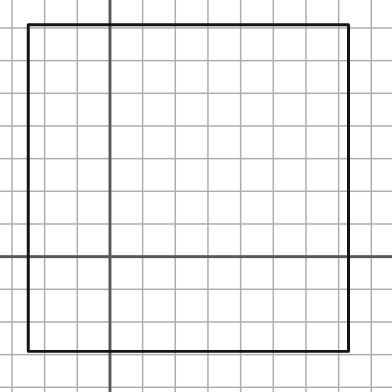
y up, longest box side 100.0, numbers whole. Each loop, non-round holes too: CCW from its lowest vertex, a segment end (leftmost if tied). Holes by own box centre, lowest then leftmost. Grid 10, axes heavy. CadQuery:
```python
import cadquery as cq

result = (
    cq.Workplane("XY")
    .moveTo(-25.0, -29.0)
    .lineTo(73.0, -29.0)
    .lineTo(73.0, 71.0)
    .lineTo(-25.0, 71.0)
    .close()
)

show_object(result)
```